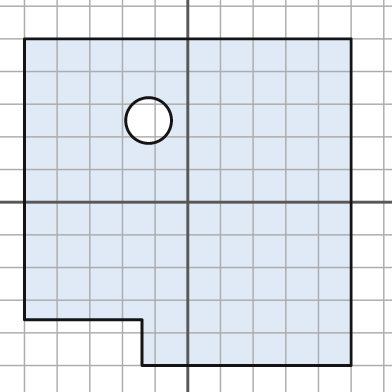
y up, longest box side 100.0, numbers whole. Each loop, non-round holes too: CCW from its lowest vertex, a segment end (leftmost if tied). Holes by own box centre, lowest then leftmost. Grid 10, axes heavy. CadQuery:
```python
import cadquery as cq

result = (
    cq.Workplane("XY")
    .moveTo(-14.0, -50.0)
    .lineTo(50.0, -50.0)
    .lineTo(50.0, 50.0)
    .lineTo(-50.0, 50.0)
    .lineTo(-50.0, -36.0)
    .lineTo(-14.0, -36.0)
    .close()
    .moveTo(-12.0, 25.0)
    .circle(7.0)
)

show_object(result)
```